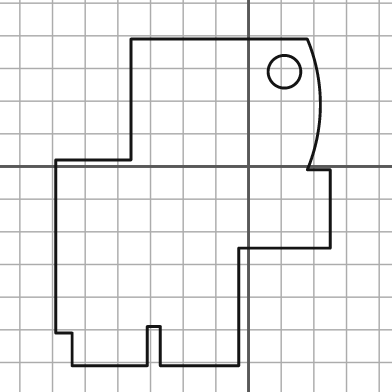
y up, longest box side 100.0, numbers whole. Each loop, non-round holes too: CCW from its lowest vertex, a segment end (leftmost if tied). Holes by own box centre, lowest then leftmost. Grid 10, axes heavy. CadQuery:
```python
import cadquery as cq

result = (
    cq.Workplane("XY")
    .moveTo(-54.0, -61.0)
    .lineTo(-31.0, -61.0)
    .lineTo(-31.0, -49.0)
    .lineTo(-27.0, -49.0)
    .lineTo(-27.0, -61.0)
    .lineTo(-3.0, -61.0)
    .lineTo(-3.0, -25.0)
    .lineTo(25.0, -25.0)
    .lineTo(25.0, -1.0)
    .lineTo(18.0, -1.0)
    .threePointArc((22.0, 19.0), (18.0, 39.0))
    .lineTo(-36.0, 39.0)
    .lineTo(-36.0, 2.0)
    .lineTo(-59.0, 2.0)
    .lineTo(-59.0, -51.0)
    .lineTo(-54.0, -51.0)
    .close()
    .moveTo(11.0, 29.0)
    .circle(5.0)
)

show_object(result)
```